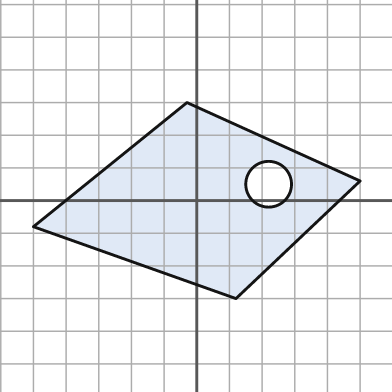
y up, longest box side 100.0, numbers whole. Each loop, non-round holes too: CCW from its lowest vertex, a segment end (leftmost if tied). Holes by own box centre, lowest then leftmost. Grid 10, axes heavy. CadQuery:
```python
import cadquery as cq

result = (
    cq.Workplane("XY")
    .moveTo(12.0, -30.0)
    .lineTo(50.0, 6.0)
    .lineTo(-3.0, 30.0)
    .lineTo(-50.0, -8.0)
    .close()
    .moveTo(22.0, 5.0)
    .circle(7.0)
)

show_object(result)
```